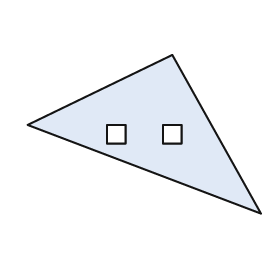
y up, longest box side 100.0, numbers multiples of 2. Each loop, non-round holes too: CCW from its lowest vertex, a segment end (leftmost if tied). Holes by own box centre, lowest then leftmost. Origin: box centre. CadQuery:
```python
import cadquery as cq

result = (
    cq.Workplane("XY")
    .moveTo(50.0, -34.0)
    .lineTo(12.0, 34.0)
    .lineTo(-50.0, 4.0)
    .close()
    .moveTo(-16.0, -4.0)
    .lineTo(-8.0, -4.0)
    .lineTo(-8.0, 4.0)
    .lineTo(-16.0, 4.0)
    .close()
    .moveTo(8.0, -4.0)
    .lineTo(16.0, -4.0)
    .lineTo(16.0, 4.0)
    .lineTo(8.0, 4.0)
    .close()
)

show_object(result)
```